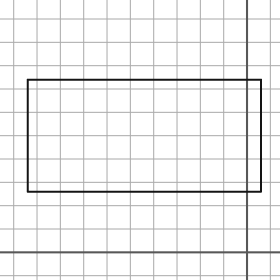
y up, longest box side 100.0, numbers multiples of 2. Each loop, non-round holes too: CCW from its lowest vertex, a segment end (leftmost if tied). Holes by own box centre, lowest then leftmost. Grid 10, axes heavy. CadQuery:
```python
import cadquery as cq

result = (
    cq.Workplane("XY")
    .moveTo(-94.0, 26.0)
    .lineTo(6.0, 26.0)
    .lineTo(6.0, 74.0)
    .lineTo(-94.0, 74.0)
    .close()
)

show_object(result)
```